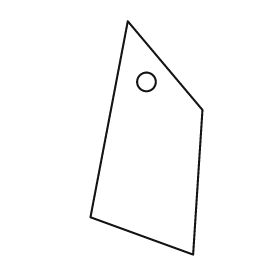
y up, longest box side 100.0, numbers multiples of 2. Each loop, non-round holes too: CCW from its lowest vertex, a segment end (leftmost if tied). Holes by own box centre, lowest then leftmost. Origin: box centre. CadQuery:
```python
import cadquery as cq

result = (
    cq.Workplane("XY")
    .moveTo(20.0, -50.0)
    .lineTo(24.0, 12.0)
    .lineTo(-8.0, 50.0)
    .lineTo(-24.0, -34.0)
    .close()
    .moveTo(0.0, 24.0)
    .circle(4.0)
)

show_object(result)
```